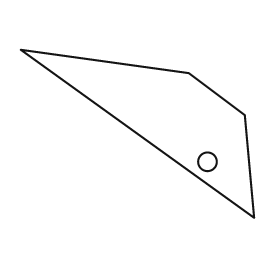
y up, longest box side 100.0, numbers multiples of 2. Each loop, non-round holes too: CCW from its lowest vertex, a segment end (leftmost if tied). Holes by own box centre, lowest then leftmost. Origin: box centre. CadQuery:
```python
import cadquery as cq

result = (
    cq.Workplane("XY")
    .moveTo(50.0, -36.0)
    .lineTo(46.0, 8.0)
    .lineTo(22.0, 26.0)
    .lineTo(-50.0, 36.0)
    .close()
    .moveTo(30.0, -12.0)
    .circle(4.0)
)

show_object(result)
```